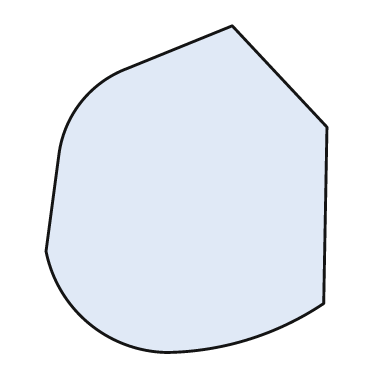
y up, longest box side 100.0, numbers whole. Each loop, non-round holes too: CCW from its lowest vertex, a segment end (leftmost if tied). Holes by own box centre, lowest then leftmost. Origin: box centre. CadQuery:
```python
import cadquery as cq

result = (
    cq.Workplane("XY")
    .moveTo(-6.0, -50.0)
    .threePointArc((19.0, -46.0), (42.0, -35.0))
    .lineTo(43.0, 19.0)
    .lineTo(14.0, 50.0)
    .lineTo(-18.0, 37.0)
    .threePointArc((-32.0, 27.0), (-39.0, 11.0))
    .lineTo(-43.0, -19.0)
    .threePointArc((-30.0, -41.0), (-6.0, -50.0))
    .close()
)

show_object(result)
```